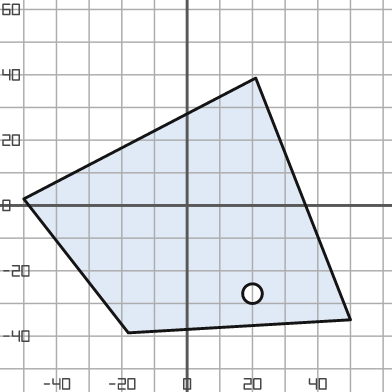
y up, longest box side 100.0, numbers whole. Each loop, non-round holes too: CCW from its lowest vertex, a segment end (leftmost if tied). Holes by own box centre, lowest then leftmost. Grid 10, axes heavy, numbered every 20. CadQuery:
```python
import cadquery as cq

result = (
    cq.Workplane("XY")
    .moveTo(-18.0, -39.0)
    .lineTo(50.0, -35.0)
    .lineTo(21.0, 39.0)
    .lineTo(-50.0, 2.0)
    .close()
    .moveTo(20.0, -27.0)
    .circle(3.0)
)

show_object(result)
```